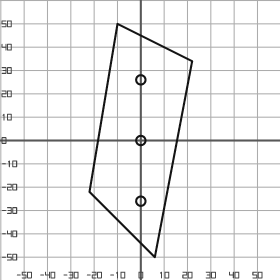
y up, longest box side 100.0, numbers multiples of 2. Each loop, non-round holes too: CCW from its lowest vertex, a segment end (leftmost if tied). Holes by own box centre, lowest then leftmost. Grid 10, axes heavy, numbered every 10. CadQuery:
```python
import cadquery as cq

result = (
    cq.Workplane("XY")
    .moveTo(6.0, -50.0)
    .lineTo(22.0, 34.0)
    .lineTo(-10.0, 50.0)
    .lineTo(-22.0, -22.0)
    .close()
    .moveTo(0.0, -26.0)
    .circle(2.0)
    .moveTo(0.0, 0.0)
    .circle(2.0)
    .moveTo(0.0, 26.0)
    .circle(2.0)
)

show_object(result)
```